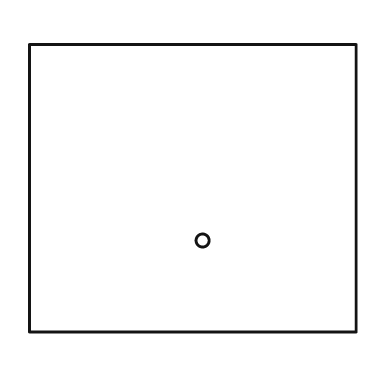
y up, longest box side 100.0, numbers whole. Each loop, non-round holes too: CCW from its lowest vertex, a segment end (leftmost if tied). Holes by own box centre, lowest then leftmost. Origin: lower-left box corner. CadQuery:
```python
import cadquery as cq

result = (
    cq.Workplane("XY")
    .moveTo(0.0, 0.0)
    .lineTo(100.0, 0.0)
    .lineTo(100.0, 88.0)
    .lineTo(0.0, 88.0)
    .close()
    .moveTo(53.0, 28.0)
    .circle(2.0)
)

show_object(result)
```